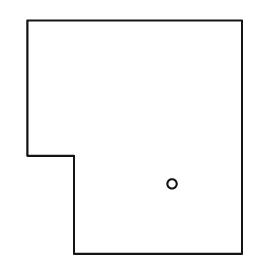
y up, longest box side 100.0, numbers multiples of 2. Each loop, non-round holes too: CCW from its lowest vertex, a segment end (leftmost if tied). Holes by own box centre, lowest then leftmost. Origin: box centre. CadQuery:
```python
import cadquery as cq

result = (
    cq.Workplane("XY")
    .moveTo(-26.0, -50.0)
    .lineTo(46.0, -50.0)
    .lineTo(46.0, 50.0)
    .lineTo(-46.0, 50.0)
    .lineTo(-46.0, -8.0)
    .lineTo(-26.0, -8.0)
    .close()
    .moveTo(16.0, -20.0)
    .circle(2.0)
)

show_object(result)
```